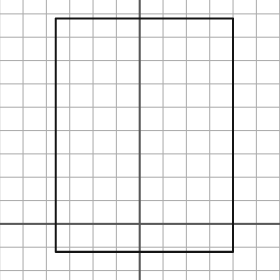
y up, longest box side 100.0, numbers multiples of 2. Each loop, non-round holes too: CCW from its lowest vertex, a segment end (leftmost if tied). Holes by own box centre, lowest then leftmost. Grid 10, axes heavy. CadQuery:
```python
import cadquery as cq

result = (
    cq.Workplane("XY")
    .moveTo(-36.0, -12.0)
    .lineTo(40.0, -12.0)
    .lineTo(40.0, 88.0)
    .lineTo(-36.0, 88.0)
    .close()
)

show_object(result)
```